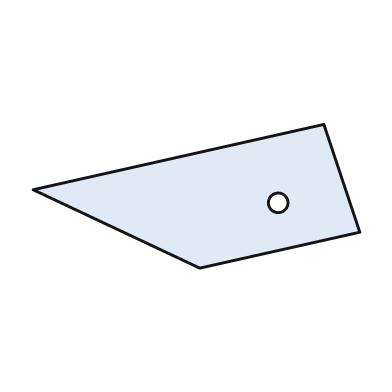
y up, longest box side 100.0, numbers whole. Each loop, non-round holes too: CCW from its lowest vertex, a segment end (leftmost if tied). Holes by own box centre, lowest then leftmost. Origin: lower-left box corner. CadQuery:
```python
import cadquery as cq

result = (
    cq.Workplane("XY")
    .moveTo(51.0, 0.0)
    .lineTo(100.0, 11.0)
    .lineTo(89.0, 44.0)
    .lineTo(0.0, 24.0)
    .close()
    .moveTo(75.0, 20.0)
    .circle(3.0)
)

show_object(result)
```